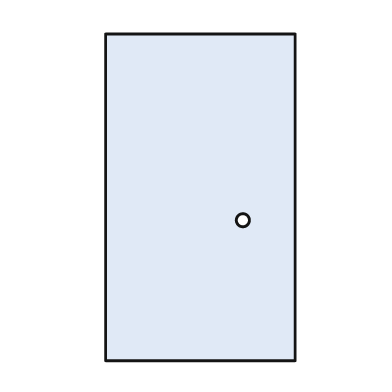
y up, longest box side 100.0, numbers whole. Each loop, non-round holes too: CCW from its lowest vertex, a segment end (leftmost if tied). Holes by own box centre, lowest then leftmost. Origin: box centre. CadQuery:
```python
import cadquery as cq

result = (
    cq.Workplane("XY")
    .moveTo(-29.0, -50.0)
    .lineTo(29.0, -50.0)
    .lineTo(29.0, 50.0)
    .lineTo(-29.0, 50.0)
    .close()
    .moveTo(13.0, -7.0)
    .circle(2.0)
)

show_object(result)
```